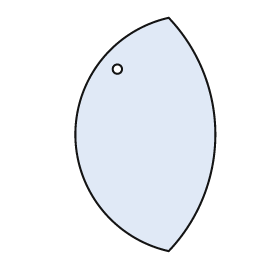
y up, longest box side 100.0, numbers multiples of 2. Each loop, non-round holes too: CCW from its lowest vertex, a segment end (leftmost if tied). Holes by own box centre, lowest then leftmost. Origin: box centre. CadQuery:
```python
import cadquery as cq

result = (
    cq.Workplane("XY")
    .moveTo(10.0, -50.0)
    .threePointArc((30.0, 0.0), (10.0, 50.0))
    .threePointArc((-30.0, 0.0), (10.0, -50.0))
    .close()
    .moveTo(-12.0, 28.0)
    .circle(2.0)
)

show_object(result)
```